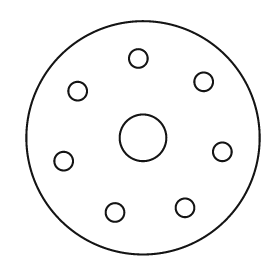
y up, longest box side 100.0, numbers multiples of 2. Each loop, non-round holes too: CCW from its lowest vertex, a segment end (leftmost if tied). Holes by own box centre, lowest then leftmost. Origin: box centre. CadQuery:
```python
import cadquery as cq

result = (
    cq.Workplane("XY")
    .moveTo(0.0, 0.0)
    .circle(50.0)
    .moveTo(-12.0, -32.0)
    .circle(4.0)
    .moveTo(18.0, -30.0)
    .circle(4.0)
    .moveTo(-34.0, -10.0)
    .circle(4.0)
    .moveTo(34.0, -6.0)
    .circle(4.0)
    .moveTo(0.0, 0.0)
    .circle(10.0)
    .moveTo(-28.0, 20.0)
    .circle(4.0)
    .moveTo(26.0, 24.0)
    .circle(4.0)
    .moveTo(-2.0, 34.0)
    .circle(4.0)
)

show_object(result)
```